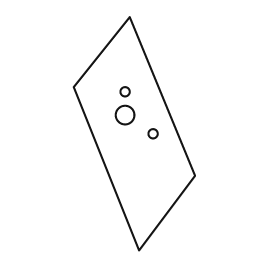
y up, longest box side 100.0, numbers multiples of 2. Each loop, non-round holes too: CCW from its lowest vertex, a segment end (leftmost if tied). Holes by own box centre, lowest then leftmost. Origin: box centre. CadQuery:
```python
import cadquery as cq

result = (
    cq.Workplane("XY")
    .moveTo(2.0, -50.0)
    .lineTo(26.0, -18.0)
    .lineTo(-2.0, 50.0)
    .lineTo(-26.0, 20.0)
    .close()
    .moveTo(8.0, 0.0)
    .circle(2.0)
    .moveTo(-4.0, 8.0)
    .circle(4.0)
    .moveTo(-4.0, 18.0)
    .circle(2.0)
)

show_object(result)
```